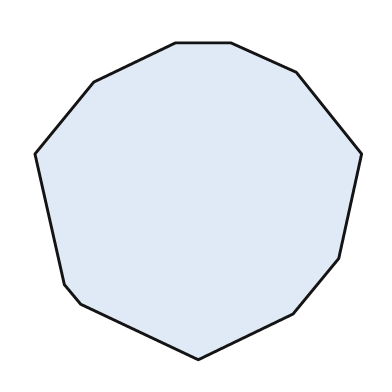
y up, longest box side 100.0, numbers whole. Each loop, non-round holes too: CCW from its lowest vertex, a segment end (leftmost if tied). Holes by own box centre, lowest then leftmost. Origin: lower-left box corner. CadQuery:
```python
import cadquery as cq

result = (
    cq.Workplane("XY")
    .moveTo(50.0, 0.0)
    .lineTo(79.0, 14.0)
    .lineTo(93.0, 31.0)
    .lineTo(100.0, 63.0)
    .lineTo(80.0, 88.0)
    .lineTo(60.0, 97.0)
    .lineTo(43.0, 97.0)
    .lineTo(18.0, 85.0)
    .lineTo(0.0, 63.0)
    .lineTo(9.0, 23.0)
    .lineTo(14.0, 17.0)
    .close()
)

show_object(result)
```